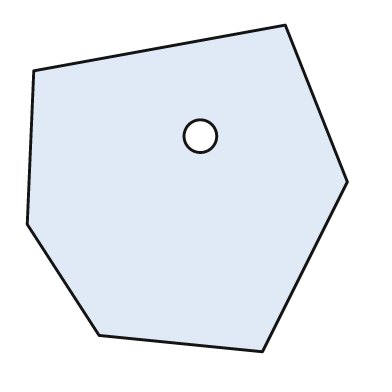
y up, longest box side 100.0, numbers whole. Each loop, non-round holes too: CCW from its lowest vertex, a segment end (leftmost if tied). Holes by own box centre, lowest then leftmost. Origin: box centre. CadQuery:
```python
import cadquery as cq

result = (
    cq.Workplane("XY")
    .moveTo(23.0, -50.0)
    .lineTo(49.0, 2.0)
    .lineTo(30.0, 50.0)
    .lineTo(-47.0, 36.0)
    .lineTo(-49.0, -11.0)
    .lineTo(-27.0, -45.0)
    .close()
    .moveTo(4.0, 16.0)
    .circle(5.0)
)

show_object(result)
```